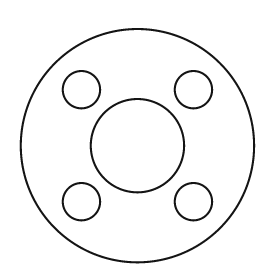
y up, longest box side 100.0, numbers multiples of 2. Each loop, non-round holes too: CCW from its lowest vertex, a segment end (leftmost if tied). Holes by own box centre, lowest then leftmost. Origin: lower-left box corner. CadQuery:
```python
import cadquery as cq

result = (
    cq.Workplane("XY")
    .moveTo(50.0, 50.0)
    .circle(50.0)
    .moveTo(26.0, 26.0)
    .circle(8.0)
    .moveTo(74.0, 26.0)
    .circle(8.0)
    .moveTo(50.0, 50.0)
    .circle(20.0)
    .moveTo(26.0, 74.0)
    .circle(8.0)
    .moveTo(74.0, 74.0)
    .circle(8.0)
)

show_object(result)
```